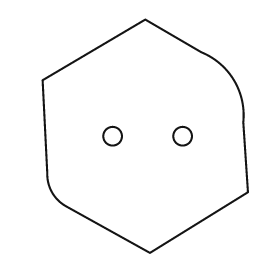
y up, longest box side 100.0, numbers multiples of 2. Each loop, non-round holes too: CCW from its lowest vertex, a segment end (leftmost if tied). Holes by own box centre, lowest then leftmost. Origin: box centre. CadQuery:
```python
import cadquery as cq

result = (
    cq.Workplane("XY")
    .moveTo(2.0, -50.0)
    .lineTo(44.0, -24.0)
    .lineTo(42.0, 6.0)
    .threePointArc((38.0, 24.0), (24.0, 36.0))
    .lineTo(0.0, 50.0)
    .lineTo(-44.0, 24.0)
    .lineTo(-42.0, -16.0)
    .threePointArc((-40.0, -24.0), (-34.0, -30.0))
    .close()
    .moveTo(-14.0, 0.0)
    .circle(4.0)
    .moveTo(16.0, 0.0)
    .circle(4.0)
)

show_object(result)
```